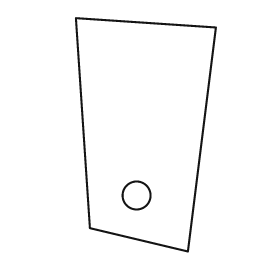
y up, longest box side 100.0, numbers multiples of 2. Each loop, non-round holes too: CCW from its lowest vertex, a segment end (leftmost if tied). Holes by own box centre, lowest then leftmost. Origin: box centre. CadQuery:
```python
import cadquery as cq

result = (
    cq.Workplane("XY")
    .moveTo(18.0, -50.0)
    .lineTo(30.0, 46.0)
    .lineTo(-30.0, 50.0)
    .lineTo(-24.0, -40.0)
    .close()
    .moveTo(-4.0, -26.0)
    .circle(6.0)
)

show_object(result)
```